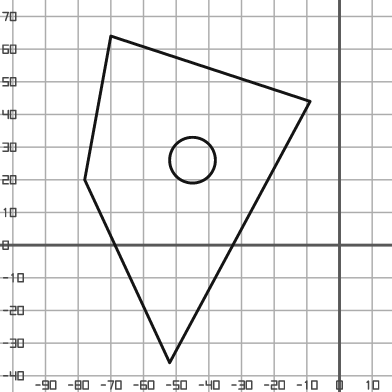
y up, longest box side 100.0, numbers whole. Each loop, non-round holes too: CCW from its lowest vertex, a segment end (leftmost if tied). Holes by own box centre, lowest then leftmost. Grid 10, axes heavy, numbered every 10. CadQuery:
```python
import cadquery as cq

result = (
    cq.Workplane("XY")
    .moveTo(-52.0, -36.0)
    .lineTo(-9.0, 44.0)
    .lineTo(-70.0, 64.0)
    .lineTo(-78.0, 20.0)
    .close()
    .moveTo(-45.0, 26.0)
    .circle(7.0)
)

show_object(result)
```